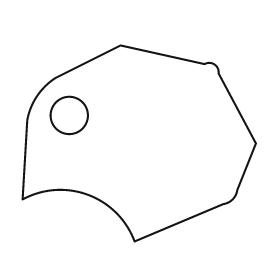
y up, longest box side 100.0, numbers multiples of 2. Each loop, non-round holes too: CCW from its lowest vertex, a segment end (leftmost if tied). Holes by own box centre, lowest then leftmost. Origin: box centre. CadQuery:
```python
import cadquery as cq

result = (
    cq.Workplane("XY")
    .moveTo(-2.0, -42.0)
    .lineTo(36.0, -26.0)
    .threePointArc((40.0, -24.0), (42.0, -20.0))
    .lineTo(50.0, 0.0)
    .lineTo(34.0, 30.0)
    .threePointArc((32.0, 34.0), (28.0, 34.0))
    .lineTo(-8.0, 42.0)
    .lineTo(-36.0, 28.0)
    .threePointArc((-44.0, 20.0), (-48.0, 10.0))
    .lineTo(-50.0, -24.0)
    .threePointArc((-22.0, -22.0), (-2.0, -42.0))
    .close()
    .moveTo(-30.0, 12.0)
    .circle(8.0)
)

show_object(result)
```